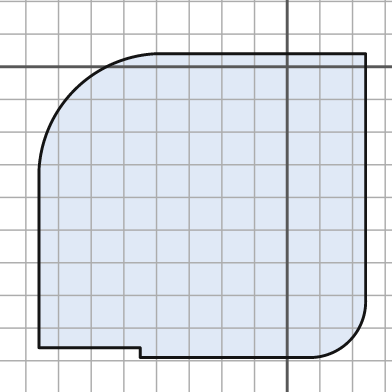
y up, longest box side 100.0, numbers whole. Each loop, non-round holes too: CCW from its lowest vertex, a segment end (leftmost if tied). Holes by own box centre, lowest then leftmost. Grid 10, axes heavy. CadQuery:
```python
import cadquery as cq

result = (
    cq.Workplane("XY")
    .moveTo(-45.0, -89.0)
    .lineTo(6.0, -89.0)
    .threePointArc((19.0, -84.0), (24.0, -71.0))
    .lineTo(24.0, 4.0)
    .lineTo(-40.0, 4.0)
    .threePointArc((-65.0, -7.0), (-76.0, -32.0))
    .lineTo(-76.0, -86.0)
    .lineTo(-45.0, -86.0)
    .close()
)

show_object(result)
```